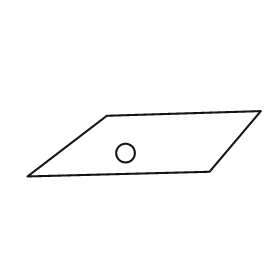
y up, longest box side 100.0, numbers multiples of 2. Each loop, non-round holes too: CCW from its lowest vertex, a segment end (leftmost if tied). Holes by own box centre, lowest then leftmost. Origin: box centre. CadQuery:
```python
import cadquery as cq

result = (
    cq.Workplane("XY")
    .moveTo(-50.0, -14.0)
    .lineTo(28.0, -12.0)
    .lineTo(50.0, 14.0)
    .lineTo(-16.0, 12.0)
    .close()
    .moveTo(-8.0, -4.0)
    .circle(4.0)
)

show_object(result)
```